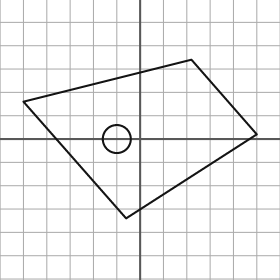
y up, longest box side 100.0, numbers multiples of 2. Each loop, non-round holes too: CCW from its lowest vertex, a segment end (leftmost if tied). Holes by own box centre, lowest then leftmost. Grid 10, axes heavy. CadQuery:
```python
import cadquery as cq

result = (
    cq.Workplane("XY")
    .moveTo(-6.0, -34.0)
    .lineTo(50.0, 2.0)
    .lineTo(22.0, 34.0)
    .lineTo(-50.0, 16.0)
    .close()
    .moveTo(-10.0, 0.0)
    .circle(6.0)
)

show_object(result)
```